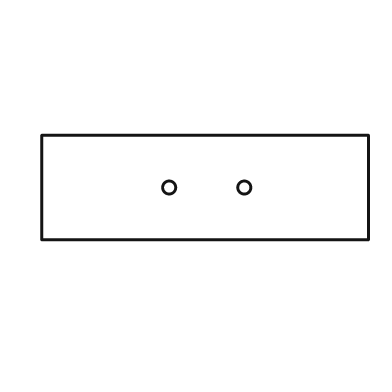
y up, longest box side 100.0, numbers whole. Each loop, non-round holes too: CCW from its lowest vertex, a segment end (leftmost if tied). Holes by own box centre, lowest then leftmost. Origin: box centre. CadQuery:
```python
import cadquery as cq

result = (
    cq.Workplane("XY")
    .moveTo(-50.0, -16.0)
    .lineTo(50.0, -16.0)
    .lineTo(50.0, 16.0)
    .lineTo(-50.0, 16.0)
    .close()
    .moveTo(-11.0, 0.0)
    .circle(2.0)
    .moveTo(12.0, 0.0)
    .circle(2.0)
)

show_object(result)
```